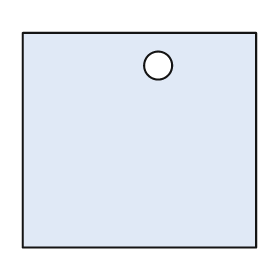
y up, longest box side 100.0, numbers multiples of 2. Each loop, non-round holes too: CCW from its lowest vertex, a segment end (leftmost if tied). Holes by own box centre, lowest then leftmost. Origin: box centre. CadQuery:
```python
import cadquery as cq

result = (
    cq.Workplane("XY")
    .moveTo(-50.0, -46.0)
    .lineTo(50.0, -46.0)
    .lineTo(50.0, 46.0)
    .lineTo(-50.0, 46.0)
    .close()
    .moveTo(8.0, 32.0)
    .circle(6.0)
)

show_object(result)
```